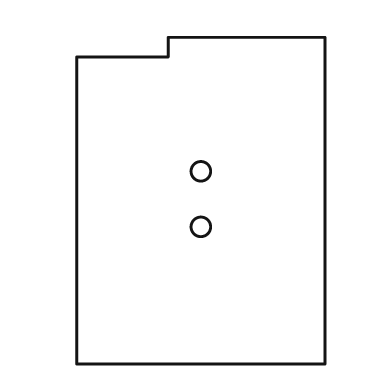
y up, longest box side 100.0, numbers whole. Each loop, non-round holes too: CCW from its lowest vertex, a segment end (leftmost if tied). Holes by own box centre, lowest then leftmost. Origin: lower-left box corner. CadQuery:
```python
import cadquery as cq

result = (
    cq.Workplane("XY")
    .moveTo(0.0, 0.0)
    .lineTo(76.0, 0.0)
    .lineTo(76.0, 100.0)
    .lineTo(28.0, 100.0)
    .lineTo(28.0, 94.0)
    .lineTo(0.0, 94.0)
    .close()
    .moveTo(38.0, 42.0)
    .circle(3.0)
    .moveTo(38.0, 59.0)
    .circle(3.0)
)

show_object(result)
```